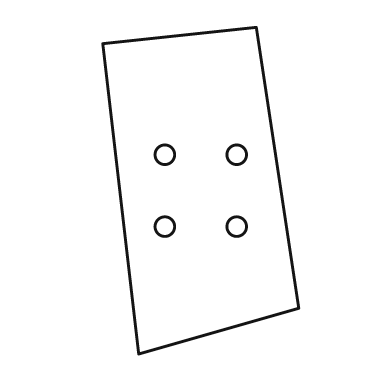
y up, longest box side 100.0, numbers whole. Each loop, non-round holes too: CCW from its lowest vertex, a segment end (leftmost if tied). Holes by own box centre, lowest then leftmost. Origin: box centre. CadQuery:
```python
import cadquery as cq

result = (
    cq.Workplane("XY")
    .moveTo(-19.0, -50.0)
    .lineTo(30.0, -36.0)
    .lineTo(17.0, 50.0)
    .lineTo(-30.0, 45.0)
    .close()
    .moveTo(-11.0, -11.0)
    .circle(3.0)
    .moveTo(11.0, -11.0)
    .circle(3.0)
    .moveTo(-11.0, 11.0)
    .circle(3.0)
    .moveTo(11.0, 11.0)
    .circle(3.0)
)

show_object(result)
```